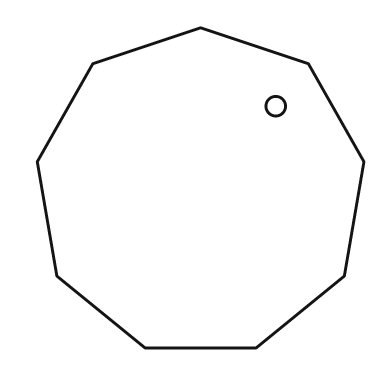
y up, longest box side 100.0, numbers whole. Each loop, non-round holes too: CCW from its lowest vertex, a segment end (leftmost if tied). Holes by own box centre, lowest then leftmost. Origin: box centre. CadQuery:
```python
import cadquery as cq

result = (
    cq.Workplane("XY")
    .moveTo(-17.0, -49.0)
    .lineTo(17.0, -49.0)
    .lineTo(44.0, -27.0)
    .lineTo(50.0, 8.0)
    .lineTo(33.0, 38.0)
    .lineTo(0.0, 49.0)
    .lineTo(-33.0, 38.0)
    .lineTo(-50.0, 8.0)
    .lineTo(-44.0, -27.0)
    .close()
    .moveTo(23.0, 25.0)
    .circle(3.0)
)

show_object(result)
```